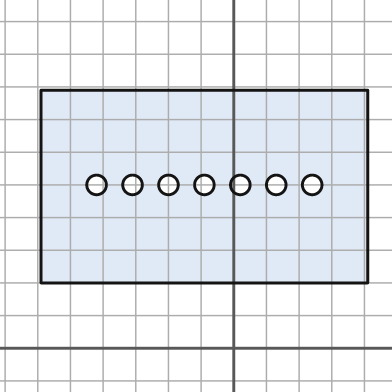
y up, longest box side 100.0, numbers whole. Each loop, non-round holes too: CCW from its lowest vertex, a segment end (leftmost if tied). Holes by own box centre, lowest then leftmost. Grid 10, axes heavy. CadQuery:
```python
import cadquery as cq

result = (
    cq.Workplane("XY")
    .moveTo(-59.0, 20.0)
    .lineTo(41.0, 20.0)
    .lineTo(41.0, 79.0)
    .lineTo(-59.0, 79.0)
    .close()
    .moveTo(-42.0, 50.0)
    .circle(3.0)
    .moveTo(-31.0, 50.0)
    .circle(3.0)
    .moveTo(-20.0, 50.0)
    .circle(3.0)
    .moveTo(-9.0, 50.0)
    .circle(3.0)
    .moveTo(2.0, 50.0)
    .circle(3.0)
    .moveTo(13.0, 50.0)
    .circle(3.0)
    .moveTo(24.0, 50.0)
    .circle(3.0)
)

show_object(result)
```